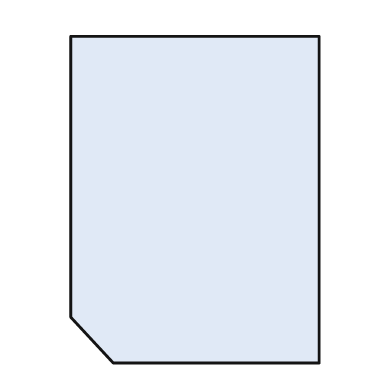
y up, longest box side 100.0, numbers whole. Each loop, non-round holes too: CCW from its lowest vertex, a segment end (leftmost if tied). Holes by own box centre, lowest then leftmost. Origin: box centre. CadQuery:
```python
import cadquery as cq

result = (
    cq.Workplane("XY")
    .moveTo(-25.0, -50.0)
    .lineTo(38.0, -50.0)
    .lineTo(38.0, 50.0)
    .lineTo(-38.0, 50.0)
    .lineTo(-38.0, -36.0)
    .close()
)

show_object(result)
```